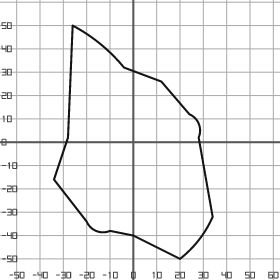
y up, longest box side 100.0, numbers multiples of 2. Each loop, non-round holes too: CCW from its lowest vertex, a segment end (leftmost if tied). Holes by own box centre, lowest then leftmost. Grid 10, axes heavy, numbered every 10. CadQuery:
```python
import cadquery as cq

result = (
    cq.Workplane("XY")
    .moveTo(20.0, -50.0)
    .threePointArc((28.0, -42.0), (34.0, -32.0))
    .lineTo(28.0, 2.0)
    .threePointArc((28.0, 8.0), (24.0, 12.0))
    .lineTo(12.0, 26.0)
    .lineTo(-4.0, 32.0)
    .threePointArc((-14.0, 42.0), (-26.0, 50.0))
    .lineTo(-28.0, 2.0)
    .lineTo(-34.0, -16.0)
    .lineTo(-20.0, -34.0)
    .threePointArc((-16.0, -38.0), (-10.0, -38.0))
    .lineTo(0.0, -40.0)
    .close()
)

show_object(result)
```